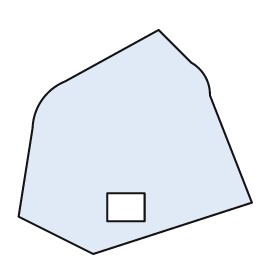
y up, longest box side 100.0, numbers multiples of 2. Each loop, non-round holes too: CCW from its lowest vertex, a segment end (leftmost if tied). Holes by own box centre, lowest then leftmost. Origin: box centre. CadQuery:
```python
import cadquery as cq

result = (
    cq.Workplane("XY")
    .moveTo(-18.0, -48.0)
    .lineTo(50.0, -26.0)
    .lineTo(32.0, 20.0)
    .threePointArc((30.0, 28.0), (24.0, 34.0))
    .lineTo(10.0, 48.0)
    .lineTo(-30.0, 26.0)
    .threePointArc((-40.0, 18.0), (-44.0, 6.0))
    .lineTo(-50.0, -32.0)
    .close()
    .moveTo(-12.0, -34.0)
    .lineTo(4.0, -34.0)
    .lineTo(4.0, -22.0)
    .lineTo(-12.0, -22.0)
    .close()
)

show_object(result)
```